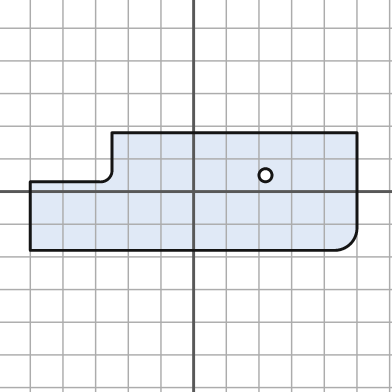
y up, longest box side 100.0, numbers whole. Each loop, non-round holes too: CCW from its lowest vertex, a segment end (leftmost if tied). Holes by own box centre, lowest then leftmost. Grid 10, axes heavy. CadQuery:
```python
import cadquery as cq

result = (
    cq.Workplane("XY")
    .moveTo(-50.0, -18.0)
    .lineTo(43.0, -18.0)
    .threePointArc((48.0, -16.0), (50.0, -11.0))
    .lineTo(50.0, 18.0)
    .lineTo(-25.0, 18.0)
    .lineTo(-25.0, 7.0)
    .threePointArc((-26.0, 4.0), (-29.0, 3.0))
    .lineTo(-50.0, 3.0)
    .close()
    .moveTo(22.0, 5.0)
    .circle(2.0)
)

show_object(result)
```